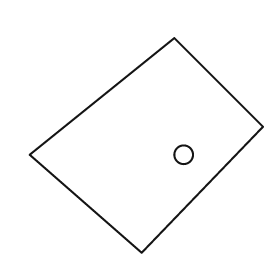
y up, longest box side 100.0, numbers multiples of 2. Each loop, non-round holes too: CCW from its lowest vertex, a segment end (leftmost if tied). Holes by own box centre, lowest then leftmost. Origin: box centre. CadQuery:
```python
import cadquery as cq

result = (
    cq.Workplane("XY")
    .moveTo(-2.0, -46.0)
    .lineTo(50.0, 8.0)
    .lineTo(12.0, 46.0)
    .lineTo(-50.0, -4.0)
    .close()
    .moveTo(16.0, -4.0)
    .circle(4.0)
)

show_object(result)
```